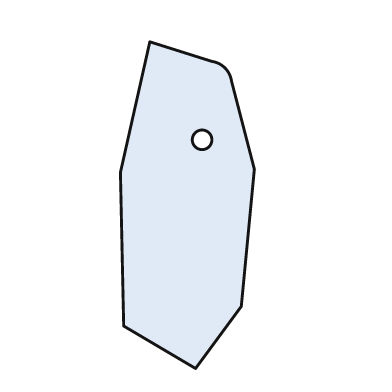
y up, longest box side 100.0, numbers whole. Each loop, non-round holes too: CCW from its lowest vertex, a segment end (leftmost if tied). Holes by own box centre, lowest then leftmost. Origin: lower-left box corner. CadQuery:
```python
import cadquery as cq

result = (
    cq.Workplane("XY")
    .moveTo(23.0, 0.0)
    .lineTo(37.0, 19.0)
    .lineTo(41.0, 61.0)
    .lineTo(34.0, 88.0)
    .threePointArc((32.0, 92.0), (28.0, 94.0))
    .lineTo(9.0, 100.0)
    .lineTo(0.0, 60.0)
    .lineTo(1.0, 13.0)
    .close()
    .moveTo(25.0, 70.0)
    .circle(3.0)
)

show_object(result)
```